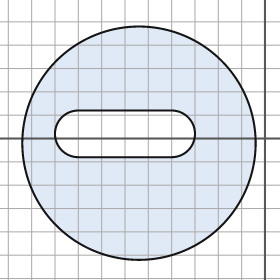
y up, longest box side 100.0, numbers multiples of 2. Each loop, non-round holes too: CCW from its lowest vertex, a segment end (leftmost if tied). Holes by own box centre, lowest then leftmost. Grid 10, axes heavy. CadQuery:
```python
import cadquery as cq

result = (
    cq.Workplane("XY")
    .moveTo(-54.0, -2.0)
    .circle(50.0)
    .moveTo(-80.0, -8.0)
    .lineTo(-40.0, -8.0)
    .threePointArc((-30.0, 2.0), (-40.0, 12.0))
    .lineTo(-80.0, 12.0)
    .threePointArc((-90.0, 2.0), (-80.0, -8.0))
    .close()
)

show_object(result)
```